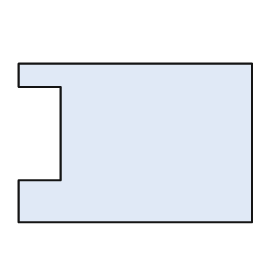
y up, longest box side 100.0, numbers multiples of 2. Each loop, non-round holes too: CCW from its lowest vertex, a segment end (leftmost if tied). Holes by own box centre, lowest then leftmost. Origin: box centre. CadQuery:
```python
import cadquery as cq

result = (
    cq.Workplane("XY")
    .moveTo(-50.0, -34.0)
    .lineTo(50.0, -34.0)
    .lineTo(50.0, 34.0)
    .lineTo(-50.0, 34.0)
    .lineTo(-50.0, 24.0)
    .lineTo(-32.0, 24.0)
    .lineTo(-32.0, -16.0)
    .lineTo(-50.0, -16.0)
    .close()
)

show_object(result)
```